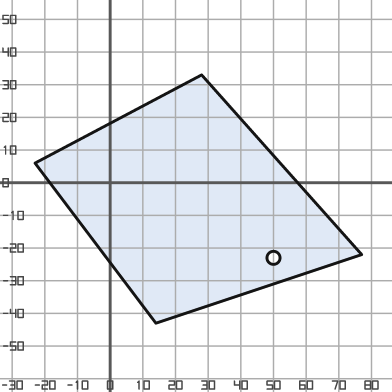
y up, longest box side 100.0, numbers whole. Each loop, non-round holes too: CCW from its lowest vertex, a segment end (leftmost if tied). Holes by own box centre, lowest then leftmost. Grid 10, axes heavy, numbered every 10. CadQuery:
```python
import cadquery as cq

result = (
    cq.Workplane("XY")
    .moveTo(14.0, -43.0)
    .lineTo(77.0, -22.0)
    .lineTo(28.0, 33.0)
    .lineTo(-23.0, 6.0)
    .close()
    .moveTo(50.0, -23.0)
    .circle(2.0)
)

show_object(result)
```